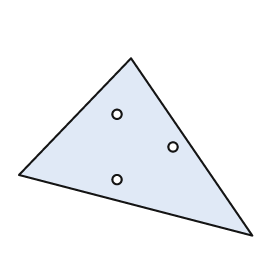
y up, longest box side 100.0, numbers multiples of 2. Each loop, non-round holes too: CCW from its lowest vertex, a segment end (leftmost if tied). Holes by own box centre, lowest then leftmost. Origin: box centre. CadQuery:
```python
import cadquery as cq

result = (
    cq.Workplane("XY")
    .moveTo(50.0, -38.0)
    .lineTo(-2.0, 38.0)
    .lineTo(-50.0, -12.0)
    .close()
    .moveTo(-8.0, -14.0)
    .circle(2.0)
    .moveTo(16.0, 0.0)
    .circle(2.0)
    .moveTo(-8.0, 14.0)
    .circle(2.0)
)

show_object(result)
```